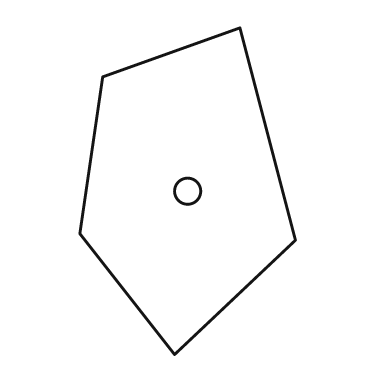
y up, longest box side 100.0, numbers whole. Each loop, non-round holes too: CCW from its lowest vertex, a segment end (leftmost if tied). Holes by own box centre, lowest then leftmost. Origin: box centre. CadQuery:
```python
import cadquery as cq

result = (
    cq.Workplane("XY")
    .moveTo(-4.0, -50.0)
    .lineTo(33.0, -15.0)
    .lineTo(16.0, 50.0)
    .lineTo(-26.0, 35.0)
    .lineTo(-33.0, -13.0)
    .close()
    .moveTo(0.0, 0.0)
    .circle(4.0)
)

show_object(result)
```